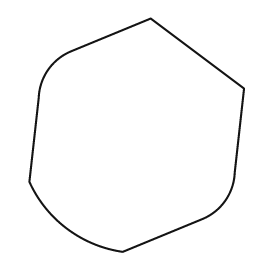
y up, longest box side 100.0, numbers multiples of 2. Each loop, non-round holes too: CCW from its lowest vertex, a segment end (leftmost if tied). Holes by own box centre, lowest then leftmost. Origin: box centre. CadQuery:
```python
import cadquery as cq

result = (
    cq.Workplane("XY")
    .moveTo(-6.0, -50.0)
    .lineTo(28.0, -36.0)
    .threePointArc((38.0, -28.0), (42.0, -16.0))
    .lineTo(46.0, 20.0)
    .lineTo(6.0, 50.0)
    .lineTo(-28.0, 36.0)
    .threePointArc((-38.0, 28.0), (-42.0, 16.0))
    .lineTo(-46.0, -20.0)
    .threePointArc((-30.0, -40.0), (-6.0, -50.0))
    .close()
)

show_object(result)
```